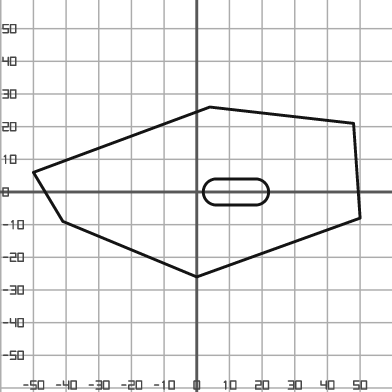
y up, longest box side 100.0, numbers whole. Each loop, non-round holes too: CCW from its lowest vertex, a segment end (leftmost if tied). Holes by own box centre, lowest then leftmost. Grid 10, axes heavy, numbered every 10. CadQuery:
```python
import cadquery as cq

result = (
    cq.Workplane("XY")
    .moveTo(0.0, -26.0)
    .lineTo(50.0, -8.0)
    .lineTo(48.0, 21.0)
    .lineTo(4.0, 26.0)
    .lineTo(-50.0, 6.0)
    .lineTo(-41.0, -9.0)
    .close()
    .moveTo(6.0, -4.0)
    .lineTo(18.0, -4.0)
    .threePointArc((22.0, 0.0), (18.0, 4.0))
    .lineTo(6.0, 4.0)
    .threePointArc((2.0, 0.0), (6.0, -4.0))
    .close()
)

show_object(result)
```